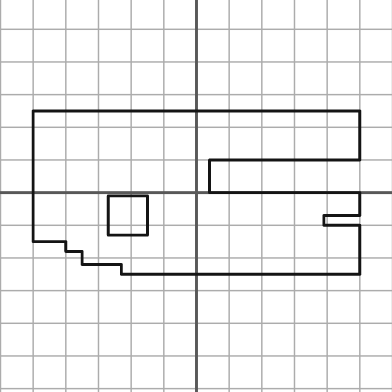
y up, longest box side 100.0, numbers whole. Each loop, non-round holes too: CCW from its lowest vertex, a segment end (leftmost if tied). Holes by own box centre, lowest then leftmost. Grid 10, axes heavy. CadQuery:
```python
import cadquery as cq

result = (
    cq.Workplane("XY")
    .moveTo(-23.0, -25.0)
    .lineTo(50.0, -25.0)
    .lineTo(50.0, -10.0)
    .lineTo(39.0, -10.0)
    .lineTo(39.0, -7.0)
    .lineTo(50.0, -7.0)
    .lineTo(50.0, 0.0)
    .lineTo(4.0, 0.0)
    .lineTo(4.0, 10.0)
    .lineTo(50.0, 10.0)
    .lineTo(50.0, 25.0)
    .lineTo(-50.0, 25.0)
    .lineTo(-50.0, -15.0)
    .lineTo(-40.0, -15.0)
    .lineTo(-40.0, -18.0)
    .lineTo(-35.0, -18.0)
    .lineTo(-35.0, -22.0)
    .lineTo(-23.0, -22.0)
    .close()
    .moveTo(-27.0, -13.0)
    .lineTo(-15.0, -13.0)
    .lineTo(-15.0, -1.0)
    .lineTo(-27.0, -1.0)
    .close()
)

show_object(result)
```